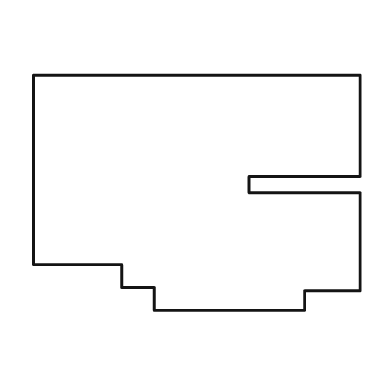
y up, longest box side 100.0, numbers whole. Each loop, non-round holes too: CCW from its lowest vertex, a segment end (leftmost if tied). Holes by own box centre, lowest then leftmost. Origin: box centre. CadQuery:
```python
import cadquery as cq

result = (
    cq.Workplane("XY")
    .moveTo(-13.0, -36.0)
    .lineTo(33.0, -36.0)
    .lineTo(33.0, -30.0)
    .lineTo(50.0, -30.0)
    .lineTo(50.0, 0.0)
    .lineTo(16.0, 0.0)
    .lineTo(16.0, 5.0)
    .lineTo(50.0, 5.0)
    .lineTo(50.0, 36.0)
    .lineTo(-50.0, 36.0)
    .lineTo(-50.0, -22.0)
    .lineTo(-23.0, -22.0)
    .lineTo(-23.0, -29.0)
    .lineTo(-13.0, -29.0)
    .close()
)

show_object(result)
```